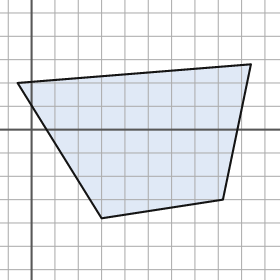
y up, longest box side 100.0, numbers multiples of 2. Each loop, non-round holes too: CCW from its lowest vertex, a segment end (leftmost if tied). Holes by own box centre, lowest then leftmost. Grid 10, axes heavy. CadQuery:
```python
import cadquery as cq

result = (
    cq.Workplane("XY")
    .moveTo(30.0, -38.0)
    .lineTo(82.0, -30.0)
    .lineTo(94.0, 28.0)
    .lineTo(-6.0, 20.0)
    .close()
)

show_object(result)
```